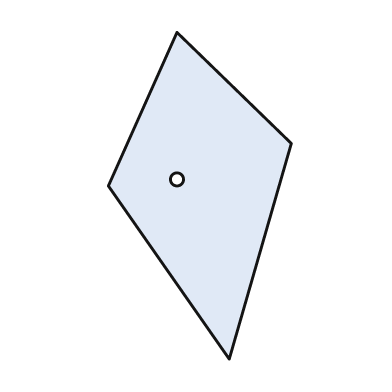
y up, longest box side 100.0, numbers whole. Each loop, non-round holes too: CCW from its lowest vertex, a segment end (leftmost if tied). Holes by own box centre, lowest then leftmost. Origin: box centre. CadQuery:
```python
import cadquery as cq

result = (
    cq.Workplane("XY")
    .moveTo(9.0, -50.0)
    .lineTo(28.0, 16.0)
    .lineTo(-7.0, 50.0)
    .lineTo(-28.0, 3.0)
    .close()
    .moveTo(-7.0, 5.0)
    .circle(2.0)
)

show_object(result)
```